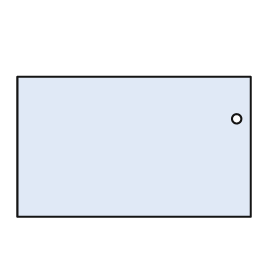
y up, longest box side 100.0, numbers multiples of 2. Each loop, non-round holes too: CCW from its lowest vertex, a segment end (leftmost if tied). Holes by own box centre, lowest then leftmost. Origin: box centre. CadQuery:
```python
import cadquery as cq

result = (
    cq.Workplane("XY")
    .moveTo(-50.0, -30.0)
    .lineTo(50.0, -30.0)
    .lineTo(50.0, 30.0)
    .lineTo(-50.0, 30.0)
    .close()
    .moveTo(44.0, 12.0)
    .circle(2.0)
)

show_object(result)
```